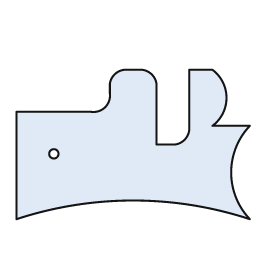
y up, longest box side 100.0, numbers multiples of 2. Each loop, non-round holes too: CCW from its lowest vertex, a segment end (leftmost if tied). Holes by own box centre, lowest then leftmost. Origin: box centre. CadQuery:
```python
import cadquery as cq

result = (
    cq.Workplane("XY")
    .moveTo(-50.0, -32.0)
    .threePointArc((0.0, -24.0), (50.0, -32.0))
    .threePointArc((42.0, -12.0), (50.0, 8.0))
    .lineTo(34.0, 8.0)
    .threePointArc((40.0, 20.0), (34.0, 32.0))
    .lineTo(24.0, 32.0)
    .lineTo(24.0, 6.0)
    .threePointArc((22.0, 2.0), (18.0, 0.0))
    .lineTo(10.0, 0.0)
    .lineTo(10.0, 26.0)
    .threePointArc((8.0, 30.0), (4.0, 32.0))
    .lineTo(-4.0, 32.0)
    .threePointArc((-8.0, 30.0), (-10.0, 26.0))
    .lineTo(-10.0, 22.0)
    .threePointArc((-12.0, 16.0), (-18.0, 14.0))
    .lineTo(-50.0, 14.0)
    .close()
    .moveTo(-34.0, -4.0)
    .circle(2.0)
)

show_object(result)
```